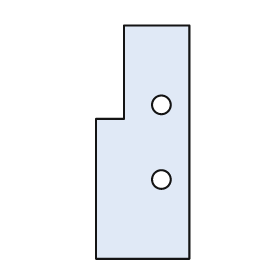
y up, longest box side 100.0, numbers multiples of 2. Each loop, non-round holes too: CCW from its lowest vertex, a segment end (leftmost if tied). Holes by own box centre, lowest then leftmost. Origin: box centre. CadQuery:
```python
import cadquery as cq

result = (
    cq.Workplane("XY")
    .moveTo(-20.0, -50.0)
    .lineTo(20.0, -50.0)
    .lineTo(20.0, 50.0)
    .lineTo(-8.0, 50.0)
    .lineTo(-8.0, 10.0)
    .lineTo(-20.0, 10.0)
    .close()
    .moveTo(8.0, -16.0)
    .circle(4.0)
    .moveTo(8.0, 16.0)
    .circle(4.0)
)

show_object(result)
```